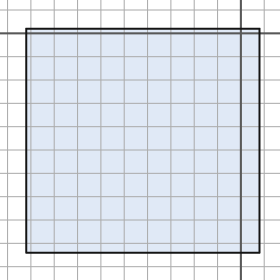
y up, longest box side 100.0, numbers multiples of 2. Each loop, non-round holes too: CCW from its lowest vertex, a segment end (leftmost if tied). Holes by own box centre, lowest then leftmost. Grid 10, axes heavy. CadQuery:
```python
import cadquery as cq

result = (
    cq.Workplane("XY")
    .moveTo(-92.0, -94.0)
    .lineTo(8.0, -94.0)
    .lineTo(8.0, 2.0)
    .lineTo(-92.0, 2.0)
    .close()
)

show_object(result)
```